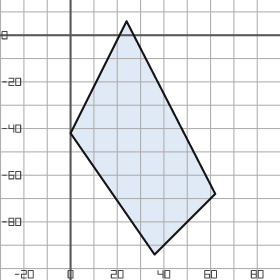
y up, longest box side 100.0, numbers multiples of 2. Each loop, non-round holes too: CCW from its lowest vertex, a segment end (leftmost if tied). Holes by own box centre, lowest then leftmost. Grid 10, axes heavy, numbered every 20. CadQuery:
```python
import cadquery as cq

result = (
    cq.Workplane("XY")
    .moveTo(36.0, -94.0)
    .lineTo(62.0, -68.0)
    .lineTo(24.0, 6.0)
    .lineTo(0.0, -42.0)
    .close()
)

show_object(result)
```